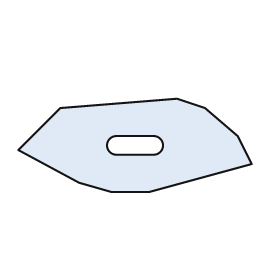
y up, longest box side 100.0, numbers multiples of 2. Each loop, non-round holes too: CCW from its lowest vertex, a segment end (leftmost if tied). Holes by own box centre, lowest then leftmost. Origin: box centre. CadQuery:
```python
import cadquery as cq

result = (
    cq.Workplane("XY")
    .moveTo(-10.0, -20.0)
    .lineTo(6.0, -20.0)
    .lineTo(50.0, -8.0)
    .lineTo(44.0, 4.0)
    .lineTo(30.0, 16.0)
    .lineTo(18.0, 20.0)
    .lineTo(-32.0, 16.0)
    .lineTo(-50.0, -2.0)
    .lineTo(-24.0, -16.0)
    .close()
    .moveTo(-8.0, -4.0)
    .lineTo(8.0, -4.0)
    .threePointArc((12.0, 0.0), (8.0, 4.0))
    .lineTo(-8.0, 4.0)
    .threePointArc((-12.0, 0.0), (-8.0, -4.0))
    .close()
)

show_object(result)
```